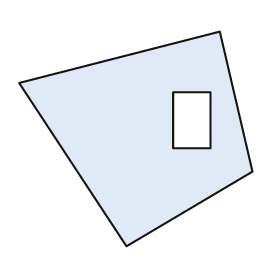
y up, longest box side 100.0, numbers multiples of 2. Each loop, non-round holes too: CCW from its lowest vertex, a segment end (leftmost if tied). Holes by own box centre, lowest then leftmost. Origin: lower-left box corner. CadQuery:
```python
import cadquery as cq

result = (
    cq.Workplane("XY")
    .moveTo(46.0, 0.0)
    .lineTo(100.0, 32.0)
    .lineTo(86.0, 92.0)
    .lineTo(0.0, 70.0)
    .close()
    .moveTo(66.0, 42.0)
    .lineTo(82.0, 42.0)
    .lineTo(82.0, 66.0)
    .lineTo(66.0, 66.0)
    .close()
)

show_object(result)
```